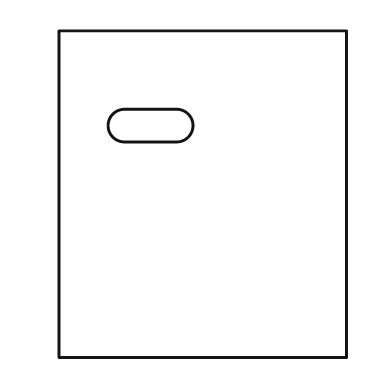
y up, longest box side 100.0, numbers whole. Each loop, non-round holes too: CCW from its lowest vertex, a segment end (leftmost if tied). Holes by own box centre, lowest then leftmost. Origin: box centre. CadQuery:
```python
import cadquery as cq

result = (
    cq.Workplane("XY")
    .moveTo(-44.0, -50.0)
    .lineTo(44.0, -50.0)
    .lineTo(44.0, 50.0)
    .lineTo(-44.0, 50.0)
    .close()
    .moveTo(-24.0, 16.0)
    .lineTo(-8.0, 16.0)
    .threePointArc((-3.0, 21.0), (-8.0, 26.0))
    .lineTo(-24.0, 26.0)
    .threePointArc((-29.0, 21.0), (-24.0, 16.0))
    .close()
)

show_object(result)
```